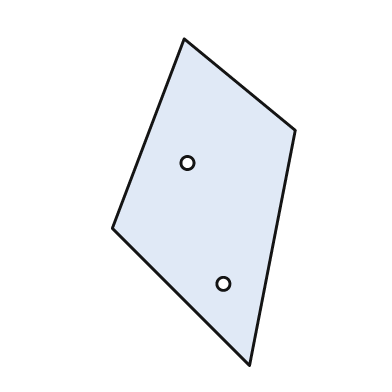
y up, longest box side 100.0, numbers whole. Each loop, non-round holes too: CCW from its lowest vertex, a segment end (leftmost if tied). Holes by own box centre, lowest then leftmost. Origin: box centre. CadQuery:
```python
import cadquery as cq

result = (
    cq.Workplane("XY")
    .moveTo(14.0, -50.0)
    .lineTo(28.0, 22.0)
    .lineTo(-6.0, 50.0)
    .lineTo(-28.0, -8.0)
    .close()
    .moveTo(6.0, -25.0)
    .circle(2.0)
    .moveTo(-5.0, 12.0)
    .circle(2.0)
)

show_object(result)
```